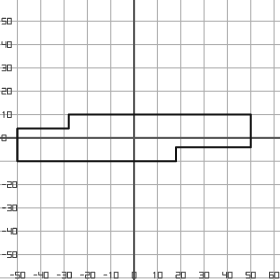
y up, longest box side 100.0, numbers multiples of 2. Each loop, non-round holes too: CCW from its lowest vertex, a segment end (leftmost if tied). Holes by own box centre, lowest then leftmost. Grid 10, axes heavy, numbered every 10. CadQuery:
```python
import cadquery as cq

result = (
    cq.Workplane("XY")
    .moveTo(-50.0, -10.0)
    .lineTo(18.0, -10.0)
    .lineTo(18.0, -4.0)
    .lineTo(50.0, -4.0)
    .lineTo(50.0, 10.0)
    .lineTo(-28.0, 10.0)
    .lineTo(-28.0, 4.0)
    .lineTo(-50.0, 4.0)
    .close()
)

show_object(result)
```